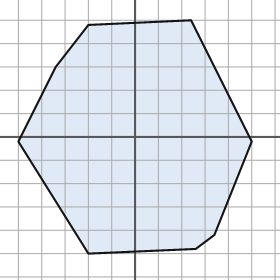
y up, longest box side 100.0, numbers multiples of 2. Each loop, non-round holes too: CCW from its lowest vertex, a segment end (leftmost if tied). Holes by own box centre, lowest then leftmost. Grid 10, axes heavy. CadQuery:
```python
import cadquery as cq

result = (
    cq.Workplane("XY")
    .moveTo(-20.0, -50.0)
    .lineTo(26.0, -48.0)
    .lineTo(34.0, -42.0)
    .lineTo(50.0, -2.0)
    .lineTo(24.0, 50.0)
    .lineTo(-20.0, 48.0)
    .lineTo(-34.0, 30.0)
    .lineTo(-50.0, -2.0)
    .close()
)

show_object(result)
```